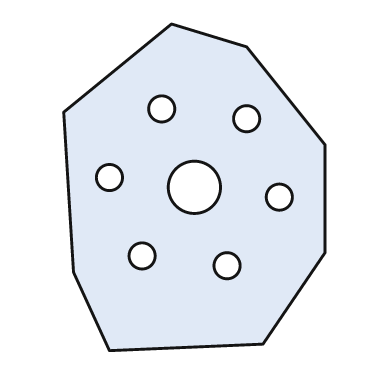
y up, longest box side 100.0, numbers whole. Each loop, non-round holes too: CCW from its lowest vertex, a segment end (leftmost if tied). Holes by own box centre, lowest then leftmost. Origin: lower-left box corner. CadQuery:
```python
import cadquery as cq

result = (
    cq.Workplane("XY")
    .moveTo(14.0, 0.0)
    .lineTo(61.0, 2.0)
    .lineTo(80.0, 30.0)
    .lineTo(80.0, 63.0)
    .lineTo(56.0, 93.0)
    .lineTo(33.0, 100.0)
    .lineTo(0.0, 73.0)
    .lineTo(3.0, 24.0)
    .close()
    .moveTo(50.0, 26.0)
    .circle(4.0)
    .moveTo(24.0, 29.0)
    .circle(4.0)
    .moveTo(66.0, 47.0)
    .circle(4.0)
    .moveTo(40.0, 50.0)
    .circle(8.0)
    .moveTo(14.0, 53.0)
    .circle(4.0)
    .moveTo(56.0, 71.0)
    .circle(4.0)
    .moveTo(30.0, 74.0)
    .circle(4.0)
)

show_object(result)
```